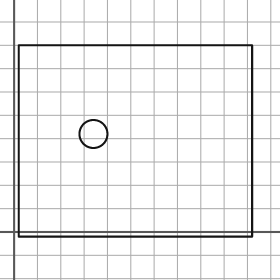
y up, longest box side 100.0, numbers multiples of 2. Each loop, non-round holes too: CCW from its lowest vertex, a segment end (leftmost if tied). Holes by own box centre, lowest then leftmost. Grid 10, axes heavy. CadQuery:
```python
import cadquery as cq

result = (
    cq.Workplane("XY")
    .moveTo(2.0, -2.0)
    .lineTo(102.0, -2.0)
    .lineTo(102.0, 80.0)
    .lineTo(2.0, 80.0)
    .close()
    .moveTo(34.0, 42.0)
    .circle(6.0)
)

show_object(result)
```